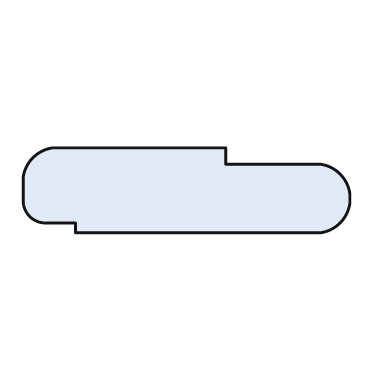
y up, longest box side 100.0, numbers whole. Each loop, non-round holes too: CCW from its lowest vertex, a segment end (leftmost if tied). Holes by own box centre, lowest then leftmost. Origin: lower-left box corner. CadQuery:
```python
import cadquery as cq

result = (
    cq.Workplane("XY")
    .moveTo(16.0, 0.0)
    .lineTo(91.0, 0.0)
    .threePointArc((97.0, 3.0), (100.0, 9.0))
    .lineTo(100.0, 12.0)
    .threePointArc((97.0, 18.0), (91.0, 21.0))
    .lineTo(62.0, 21.0)
    .lineTo(62.0, 26.0)
    .lineTo(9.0, 26.0)
    .threePointArc((3.0, 23.0), (0.0, 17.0))
    .lineTo(0.0, 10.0)
    .threePointArc((2.0, 5.0), (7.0, 3.0))
    .lineTo(16.0, 3.0)
    .close()
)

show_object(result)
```